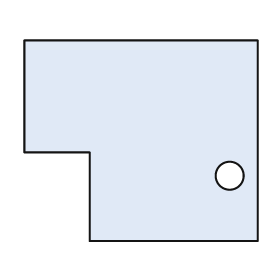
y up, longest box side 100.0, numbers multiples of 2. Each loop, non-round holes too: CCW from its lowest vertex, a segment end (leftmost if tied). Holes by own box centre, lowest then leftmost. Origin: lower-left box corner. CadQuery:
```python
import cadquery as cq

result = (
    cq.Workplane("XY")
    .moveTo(28.0, 0.0)
    .lineTo(100.0, 0.0)
    .lineTo(100.0, 86.0)
    .lineTo(0.0, 86.0)
    .lineTo(0.0, 38.0)
    .lineTo(28.0, 38.0)
    .close()
    .moveTo(88.0, 28.0)
    .circle(6.0)
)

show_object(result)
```